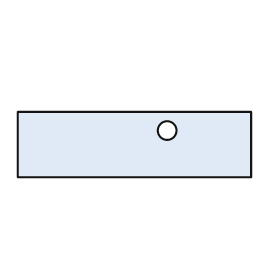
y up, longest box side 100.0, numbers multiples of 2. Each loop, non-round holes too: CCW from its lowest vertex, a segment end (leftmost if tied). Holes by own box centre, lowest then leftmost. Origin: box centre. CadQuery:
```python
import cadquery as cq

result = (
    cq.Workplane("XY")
    .moveTo(-50.0, -14.0)
    .lineTo(50.0, -14.0)
    .lineTo(50.0, 14.0)
    .lineTo(-50.0, 14.0)
    .close()
    .moveTo(14.0, 6.0)
    .circle(4.0)
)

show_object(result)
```